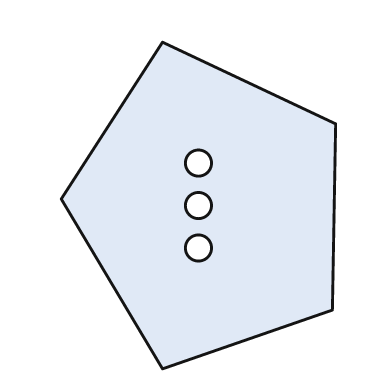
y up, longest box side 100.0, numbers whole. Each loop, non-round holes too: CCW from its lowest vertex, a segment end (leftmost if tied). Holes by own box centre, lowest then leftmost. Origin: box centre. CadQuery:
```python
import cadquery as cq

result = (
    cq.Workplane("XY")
    .moveTo(-11.0, -50.0)
    .lineTo(41.0, -32.0)
    .lineTo(42.0, 25.0)
    .lineTo(-11.0, 50.0)
    .lineTo(-42.0, 2.0)
    .close()
    .moveTo(0.0, -13.0)
    .circle(4.0)
    .moveTo(0.0, 0.0)
    .circle(4.0)
    .moveTo(0.0, 13.0)
    .circle(4.0)
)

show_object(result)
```